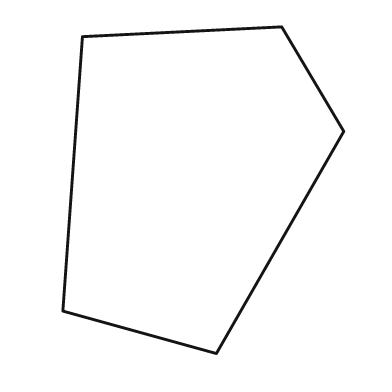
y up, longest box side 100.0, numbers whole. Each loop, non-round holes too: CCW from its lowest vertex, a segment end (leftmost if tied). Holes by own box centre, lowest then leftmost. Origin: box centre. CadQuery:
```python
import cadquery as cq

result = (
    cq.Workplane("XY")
    .moveTo(4.0, -50.0)
    .lineTo(43.0, 18.0)
    .lineTo(24.0, 50.0)
    .lineTo(-37.0, 47.0)
    .lineTo(-43.0, -37.0)
    .close()
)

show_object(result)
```